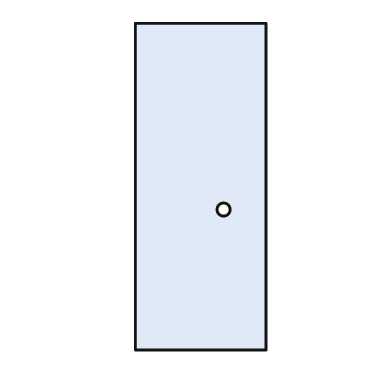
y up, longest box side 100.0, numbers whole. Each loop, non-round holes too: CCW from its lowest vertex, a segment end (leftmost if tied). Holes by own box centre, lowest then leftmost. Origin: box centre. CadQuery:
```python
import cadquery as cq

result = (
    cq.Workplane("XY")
    .moveTo(-20.0, -50.0)
    .lineTo(20.0, -50.0)
    .lineTo(20.0, 50.0)
    .lineTo(-20.0, 50.0)
    .close()
    .moveTo(7.0, -7.0)
    .circle(2.0)
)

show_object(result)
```